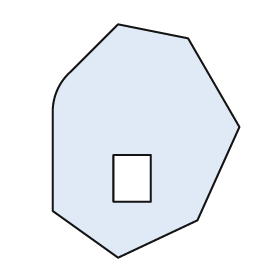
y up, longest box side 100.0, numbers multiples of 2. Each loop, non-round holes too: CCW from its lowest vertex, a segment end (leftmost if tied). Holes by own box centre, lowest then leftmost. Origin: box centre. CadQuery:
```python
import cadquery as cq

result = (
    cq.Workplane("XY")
    .moveTo(-12.0, -50.0)
    .lineTo(22.0, -34.0)
    .lineTo(40.0, 6.0)
    .lineTo(18.0, 44.0)
    .lineTo(-12.0, 50.0)
    .lineTo(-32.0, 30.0)
    .threePointArc((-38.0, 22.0), (-40.0, 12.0))
    .lineTo(-40.0, -30.0)
    .close()
    .moveTo(-14.0, -26.0)
    .lineTo(2.0, -26.0)
    .lineTo(2.0, -6.0)
    .lineTo(-14.0, -6.0)
    .close()
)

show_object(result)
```